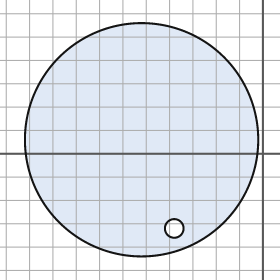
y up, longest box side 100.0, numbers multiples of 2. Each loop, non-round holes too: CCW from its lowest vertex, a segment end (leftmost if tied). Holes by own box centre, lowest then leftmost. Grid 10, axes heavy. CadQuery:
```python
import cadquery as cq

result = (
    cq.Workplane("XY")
    .moveTo(-52.0, 6.0)
    .circle(50.0)
    .moveTo(-38.0, -32.0)
    .circle(4.0)
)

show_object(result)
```